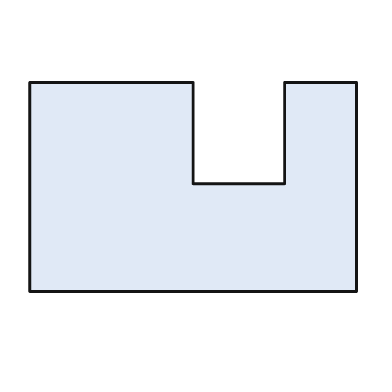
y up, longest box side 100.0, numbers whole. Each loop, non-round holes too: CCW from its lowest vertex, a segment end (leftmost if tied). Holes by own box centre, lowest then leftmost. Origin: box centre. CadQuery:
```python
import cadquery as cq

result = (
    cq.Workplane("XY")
    .moveTo(-50.0, -32.0)
    .lineTo(50.0, -32.0)
    .lineTo(50.0, 32.0)
    .lineTo(28.0, 32.0)
    .lineTo(28.0, 1.0)
    .lineTo(0.0, 1.0)
    .lineTo(0.0, 32.0)
    .lineTo(-50.0, 32.0)
    .close()
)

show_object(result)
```